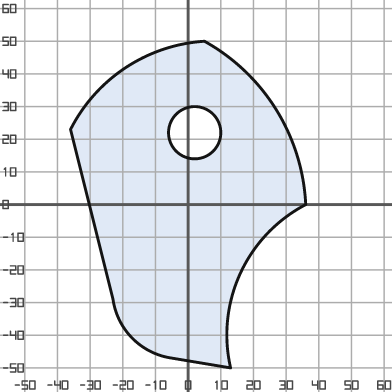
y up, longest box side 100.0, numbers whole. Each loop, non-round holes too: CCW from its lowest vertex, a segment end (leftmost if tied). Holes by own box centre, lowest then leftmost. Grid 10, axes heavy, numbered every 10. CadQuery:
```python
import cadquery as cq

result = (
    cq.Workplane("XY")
    .moveTo(13.0, -50.0)
    .threePointArc((16.0, -21.0), (36.0, 0.0))
    .threePointArc((27.0, 29.0), (5.0, 50.0))
    .threePointArc((-19.0, 42.0), (-36.0, 23.0))
    .lineTo(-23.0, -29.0)
    .threePointArc((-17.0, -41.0), (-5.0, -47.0))
    .close()
    .moveTo(2.0, 22.0)
    .circle(8.0)
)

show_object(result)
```